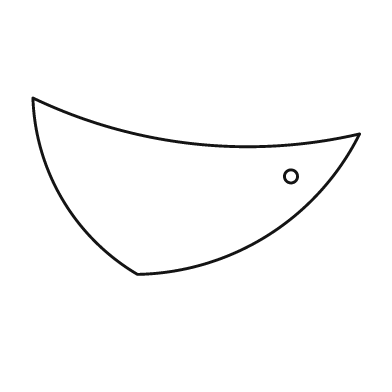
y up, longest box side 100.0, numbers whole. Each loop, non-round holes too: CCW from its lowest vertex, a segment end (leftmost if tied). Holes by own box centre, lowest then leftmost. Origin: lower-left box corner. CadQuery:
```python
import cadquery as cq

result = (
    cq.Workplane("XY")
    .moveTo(32.0, 0.0)
    .threePointArc((72.0, 12.0), (100.0, 43.0))
    .threePointArc((49.0, 40.0), (0.0, 54.0))
    .threePointArc((9.0, 23.0), (32.0, 0.0))
    .close()
    .moveTo(79.0, 30.0)
    .circle(2.0)
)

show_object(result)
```